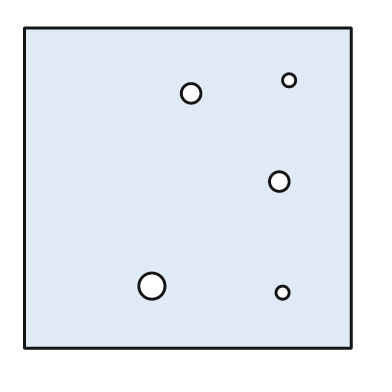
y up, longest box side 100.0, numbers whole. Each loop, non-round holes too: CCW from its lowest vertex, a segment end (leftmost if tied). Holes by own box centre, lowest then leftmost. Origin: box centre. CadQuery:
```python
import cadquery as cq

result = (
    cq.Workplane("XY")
    .moveTo(-50.0, -49.0)
    .lineTo(50.0, -49.0)
    .lineTo(50.0, 49.0)
    .lineTo(-50.0, 49.0)
    .close()
    .moveTo(29.0, -32.0)
    .circle(2.0)
    .moveTo(-11.0, -30.0)
    .circle(4.0)
    .moveTo(28.0, 2.0)
    .circle(3.0)
    .moveTo(1.0, 29.0)
    .circle(3.0)
    .moveTo(31.0, 33.0)
    .circle(2.0)
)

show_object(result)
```